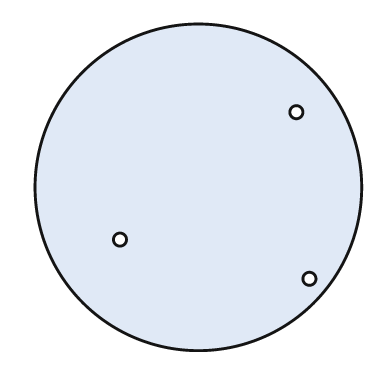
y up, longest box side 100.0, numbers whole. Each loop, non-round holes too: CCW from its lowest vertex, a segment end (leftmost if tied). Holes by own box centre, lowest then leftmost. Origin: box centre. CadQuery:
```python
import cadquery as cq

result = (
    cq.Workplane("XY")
    .moveTo(0.0, 0.0)
    .circle(50.0)
    .moveTo(34.0, -28.0)
    .circle(2.0)
    .moveTo(-24.0, -16.0)
    .circle(2.0)
    .moveTo(30.0, 23.0)
    .circle(2.0)
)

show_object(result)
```